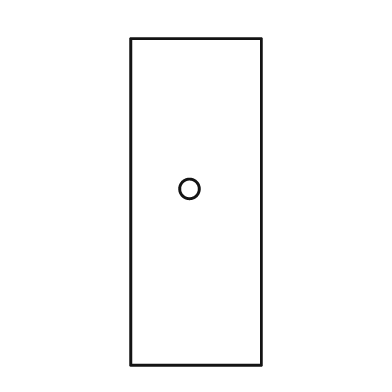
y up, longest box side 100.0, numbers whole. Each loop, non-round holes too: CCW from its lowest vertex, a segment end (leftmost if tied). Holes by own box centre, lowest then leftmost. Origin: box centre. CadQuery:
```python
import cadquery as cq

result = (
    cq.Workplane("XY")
    .moveTo(-20.0, -50.0)
    .lineTo(20.0, -50.0)
    .lineTo(20.0, 50.0)
    .lineTo(-20.0, 50.0)
    .close()
    .moveTo(-2.0, 4.0)
    .circle(3.0)
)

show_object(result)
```